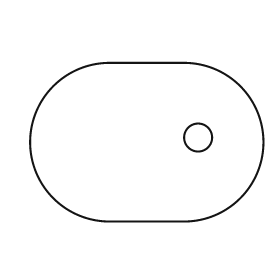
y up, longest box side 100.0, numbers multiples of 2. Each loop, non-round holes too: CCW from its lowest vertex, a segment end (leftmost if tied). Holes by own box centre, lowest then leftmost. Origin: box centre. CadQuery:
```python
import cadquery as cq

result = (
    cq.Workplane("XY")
    .moveTo(-16.0, -34.0)
    .lineTo(16.0, -34.0)
    .threePointArc((50.0, 0.0), (16.0, 34.0))
    .lineTo(-16.0, 34.0)
    .threePointArc((-50.0, 0.0), (-16.0, -34.0))
    .close()
    .moveTo(22.0, 2.0)
    .circle(6.0)
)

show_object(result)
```